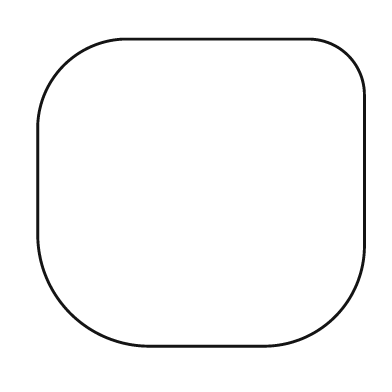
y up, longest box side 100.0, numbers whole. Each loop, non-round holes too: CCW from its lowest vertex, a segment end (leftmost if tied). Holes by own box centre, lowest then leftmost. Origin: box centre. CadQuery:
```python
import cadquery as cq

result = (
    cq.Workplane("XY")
    .moveTo(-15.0, -47.0)
    .lineTo(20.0, -47.0)
    .threePointArc((41.0, -38.0), (50.0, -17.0))
    .lineTo(50.0, 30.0)
    .threePointArc((45.0, 42.0), (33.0, 47.0))
    .lineTo(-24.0, 47.0)
    .threePointArc((-42.0, 39.0), (-50.0, 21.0))
    .lineTo(-50.0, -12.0)
    .threePointArc((-40.0, -37.0), (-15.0, -47.0))
    .close()
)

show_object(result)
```